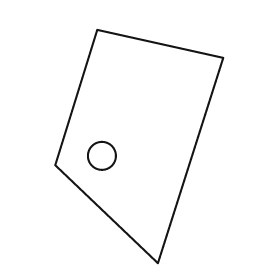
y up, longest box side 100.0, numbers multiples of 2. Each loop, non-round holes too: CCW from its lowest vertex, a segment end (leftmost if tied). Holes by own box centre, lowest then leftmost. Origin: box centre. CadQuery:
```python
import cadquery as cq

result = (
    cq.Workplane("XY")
    .moveTo(8.0, -50.0)
    .lineTo(36.0, 38.0)
    .lineTo(-18.0, 50.0)
    .lineTo(-36.0, -8.0)
    .close()
    .moveTo(-16.0, -4.0)
    .circle(6.0)
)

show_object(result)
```